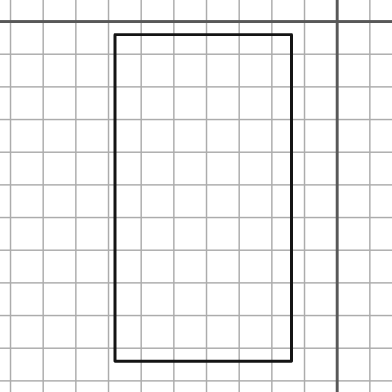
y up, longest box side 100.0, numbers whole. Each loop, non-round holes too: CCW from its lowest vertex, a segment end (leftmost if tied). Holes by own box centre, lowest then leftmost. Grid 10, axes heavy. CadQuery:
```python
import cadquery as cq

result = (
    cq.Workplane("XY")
    .moveTo(-68.0, -104.0)
    .lineTo(-14.0, -104.0)
    .lineTo(-14.0, -4.0)
    .lineTo(-68.0, -4.0)
    .close()
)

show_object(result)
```